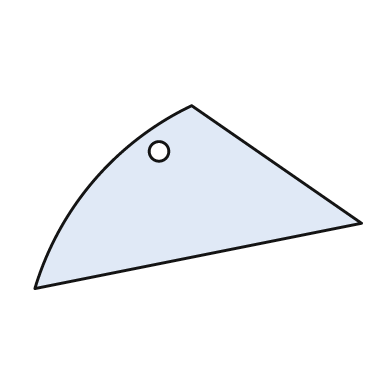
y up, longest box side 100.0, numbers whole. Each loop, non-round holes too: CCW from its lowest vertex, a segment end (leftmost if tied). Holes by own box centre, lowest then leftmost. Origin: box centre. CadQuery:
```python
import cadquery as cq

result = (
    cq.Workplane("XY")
    .moveTo(-50.0, -28.0)
    .lineTo(50.0, -8.0)
    .lineTo(-2.0, 28.0)
    .threePointArc((-32.0, 5.0), (-50.0, -28.0))
    .close()
    .moveTo(-12.0, 14.0)
    .circle(3.0)
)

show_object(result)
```